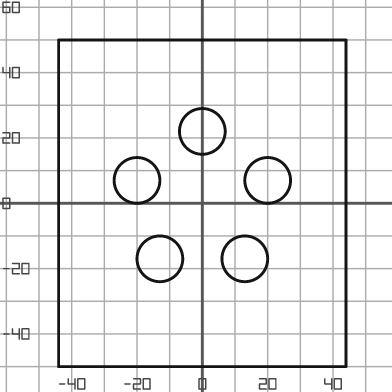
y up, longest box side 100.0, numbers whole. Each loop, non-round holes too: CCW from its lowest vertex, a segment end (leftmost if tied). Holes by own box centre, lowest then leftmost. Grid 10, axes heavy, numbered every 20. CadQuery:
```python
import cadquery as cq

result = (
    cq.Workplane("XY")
    .moveTo(-44.0, -50.0)
    .lineTo(44.0, -50.0)
    .lineTo(44.0, 50.0)
    .lineTo(-44.0, 50.0)
    .close()
    .moveTo(-13.0, -17.0)
    .circle(7.0)
    .moveTo(13.0, -17.0)
    .circle(7.0)
    .moveTo(-20.0, 7.0)
    .circle(7.0)
    .moveTo(20.0, 7.0)
    .circle(7.0)
    .moveTo(0.0, 22.0)
    .circle(7.0)
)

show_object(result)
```